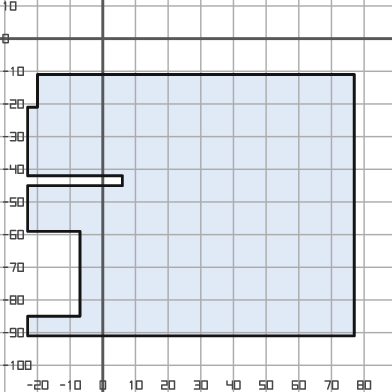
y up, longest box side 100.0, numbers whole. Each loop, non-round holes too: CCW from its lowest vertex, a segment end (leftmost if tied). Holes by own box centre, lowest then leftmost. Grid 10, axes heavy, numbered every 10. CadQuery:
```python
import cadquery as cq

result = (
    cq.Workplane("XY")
    .moveTo(-23.0, -91.0)
    .lineTo(77.0, -91.0)
    .lineTo(77.0, -11.0)
    .lineTo(-20.0, -11.0)
    .lineTo(-20.0, -21.0)
    .lineTo(-23.0, -21.0)
    .lineTo(-23.0, -42.0)
    .lineTo(6.0, -42.0)
    .lineTo(6.0, -45.0)
    .lineTo(-23.0, -45.0)
    .lineTo(-23.0, -59.0)
    .lineTo(-7.0, -59.0)
    .lineTo(-7.0, -85.0)
    .lineTo(-23.0, -85.0)
    .close()
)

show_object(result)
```